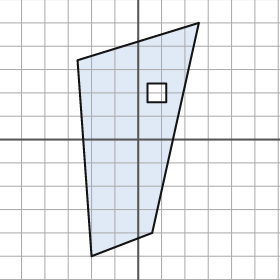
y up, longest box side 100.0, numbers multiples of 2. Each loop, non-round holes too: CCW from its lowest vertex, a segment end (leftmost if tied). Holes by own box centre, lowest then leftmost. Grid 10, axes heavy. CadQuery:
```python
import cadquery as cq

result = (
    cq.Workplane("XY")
    .moveTo(-20.0, -50.0)
    .lineTo(6.0, -40.0)
    .lineTo(26.0, 50.0)
    .lineTo(-26.0, 34.0)
    .close()
    .moveTo(4.0, 16.0)
    .lineTo(12.0, 16.0)
    .lineTo(12.0, 24.0)
    .lineTo(4.0, 24.0)
    .close()
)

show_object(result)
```